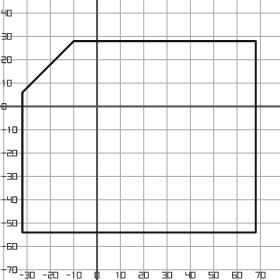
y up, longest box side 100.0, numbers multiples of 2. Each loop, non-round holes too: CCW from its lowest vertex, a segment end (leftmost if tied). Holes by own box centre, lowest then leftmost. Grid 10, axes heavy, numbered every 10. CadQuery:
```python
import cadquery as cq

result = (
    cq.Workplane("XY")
    .moveTo(-32.0, -54.0)
    .lineTo(68.0, -54.0)
    .lineTo(68.0, 28.0)
    .lineTo(-10.0, 28.0)
    .lineTo(-32.0, 6.0)
    .close()
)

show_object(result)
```